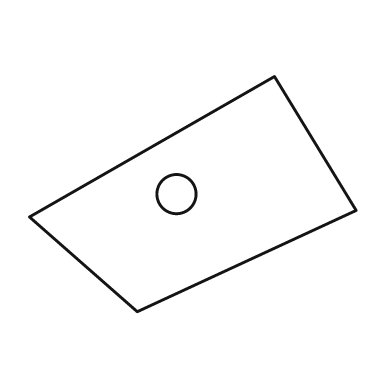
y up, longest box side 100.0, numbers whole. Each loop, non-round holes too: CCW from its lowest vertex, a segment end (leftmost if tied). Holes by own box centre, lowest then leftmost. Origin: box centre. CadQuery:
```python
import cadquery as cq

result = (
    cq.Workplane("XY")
    .moveTo(-17.0, -36.0)
    .lineTo(50.0, -5.0)
    .lineTo(25.0, 36.0)
    .lineTo(-50.0, -7.0)
    .close()
    .moveTo(-5.0, 0.0)
    .circle(6.0)
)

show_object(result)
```